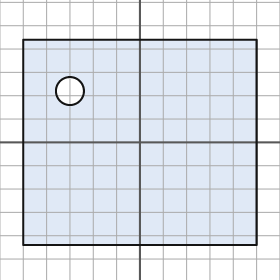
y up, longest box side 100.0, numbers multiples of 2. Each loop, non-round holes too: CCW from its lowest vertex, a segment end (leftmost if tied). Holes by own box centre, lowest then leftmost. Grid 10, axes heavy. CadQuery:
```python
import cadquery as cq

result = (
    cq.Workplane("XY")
    .moveTo(-50.0, -44.0)
    .lineTo(50.0, -44.0)
    .lineTo(50.0, 44.0)
    .lineTo(-50.0, 44.0)
    .close()
    .moveTo(-30.0, 22.0)
    .circle(6.0)
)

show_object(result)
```